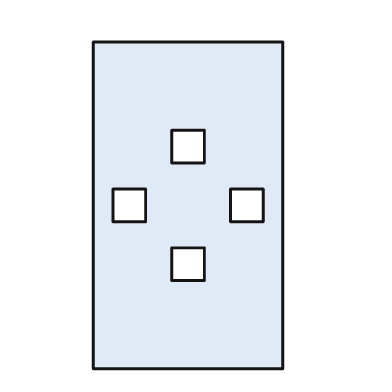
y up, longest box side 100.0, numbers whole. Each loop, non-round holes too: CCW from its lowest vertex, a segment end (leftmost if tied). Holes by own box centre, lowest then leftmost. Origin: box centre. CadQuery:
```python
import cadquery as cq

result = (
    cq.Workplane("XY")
    .moveTo(-29.0, -50.0)
    .lineTo(29.0, -50.0)
    .lineTo(29.0, 50.0)
    .lineTo(-29.0, 50.0)
    .close()
    .moveTo(-5.0, -23.0)
    .lineTo(5.0, -23.0)
    .lineTo(5.0, -13.0)
    .lineTo(-5.0, -13.0)
    .close()
    .moveTo(-23.0, -5.0)
    .lineTo(-13.0, -5.0)
    .lineTo(-13.0, 5.0)
    .lineTo(-23.0, 5.0)
    .close()
    .moveTo(13.0, -5.0)
    .lineTo(23.0, -5.0)
    .lineTo(23.0, 5.0)
    .lineTo(13.0, 5.0)
    .close()
    .moveTo(-5.0, 13.0)
    .lineTo(5.0, 13.0)
    .lineTo(5.0, 23.0)
    .lineTo(-5.0, 23.0)
    .close()
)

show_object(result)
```